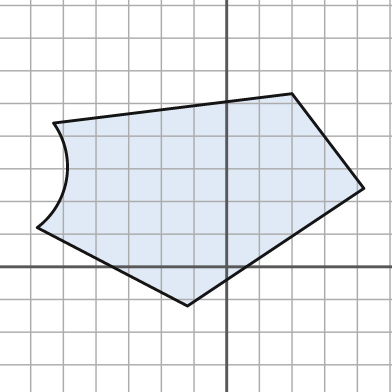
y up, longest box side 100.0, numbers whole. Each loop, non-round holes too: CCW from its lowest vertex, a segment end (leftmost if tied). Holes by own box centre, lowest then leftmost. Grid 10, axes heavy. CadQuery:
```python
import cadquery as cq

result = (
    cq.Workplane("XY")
    .moveTo(-12.0, -12.0)
    .lineTo(42.0, 24.0)
    .lineTo(20.0, 53.0)
    .lineTo(-53.0, 44.0)
    .threePointArc((-49.0, 27.0), (-58.0, 12.0))
    .close()
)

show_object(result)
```